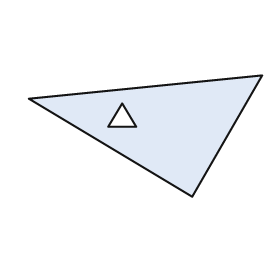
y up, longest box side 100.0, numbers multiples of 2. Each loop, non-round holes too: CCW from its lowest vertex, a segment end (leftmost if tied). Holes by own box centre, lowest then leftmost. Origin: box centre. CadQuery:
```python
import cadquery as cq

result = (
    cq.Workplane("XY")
    .moveTo(20.0, -26.0)
    .lineTo(50.0, 26.0)
    .lineTo(-50.0, 16.0)
    .close()
    .moveTo(-16.0, 4.0)
    .lineTo(-4.0, 4.0)
    .lineTo(-10.0, 14.0)
    .close()
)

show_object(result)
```